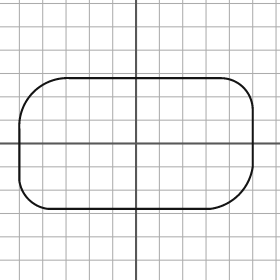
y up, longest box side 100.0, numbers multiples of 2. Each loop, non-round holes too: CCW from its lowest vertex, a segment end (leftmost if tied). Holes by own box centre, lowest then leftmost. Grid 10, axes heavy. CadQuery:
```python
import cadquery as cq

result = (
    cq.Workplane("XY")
    .moveTo(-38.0, -28.0)
    .lineTo(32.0, -28.0)
    .threePointArc((44.0, -22.0), (50.0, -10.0))
    .lineTo(50.0, 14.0)
    .threePointArc((46.0, 24.0), (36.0, 28.0))
    .lineTo(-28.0, 28.0)
    .threePointArc((-44.0, 22.0), (-50.0, 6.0))
    .lineTo(-50.0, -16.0)
    .threePointArc((-46.0, -24.0), (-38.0, -28.0))
    .close()
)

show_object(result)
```